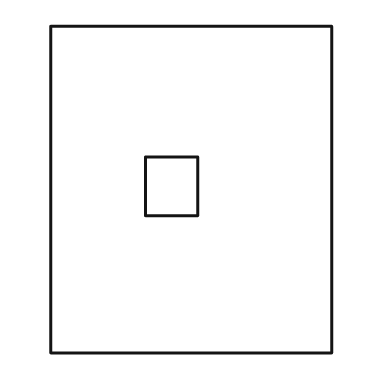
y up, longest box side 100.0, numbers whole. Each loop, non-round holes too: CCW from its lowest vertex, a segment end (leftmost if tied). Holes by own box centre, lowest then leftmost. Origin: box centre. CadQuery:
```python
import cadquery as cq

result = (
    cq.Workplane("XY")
    .moveTo(-43.0, -50.0)
    .lineTo(43.0, -50.0)
    .lineTo(43.0, 50.0)
    .lineTo(-43.0, 50.0)
    .close()
    .moveTo(-14.0, -8.0)
    .lineTo(2.0, -8.0)
    .lineTo(2.0, 10.0)
    .lineTo(-14.0, 10.0)
    .close()
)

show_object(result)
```